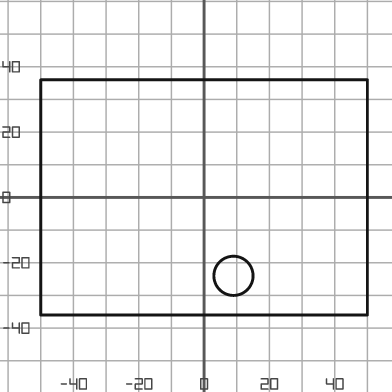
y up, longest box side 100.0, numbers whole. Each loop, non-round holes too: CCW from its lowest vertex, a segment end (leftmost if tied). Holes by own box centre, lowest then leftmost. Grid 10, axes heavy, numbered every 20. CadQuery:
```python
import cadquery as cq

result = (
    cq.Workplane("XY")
    .moveTo(-50.0, -36.0)
    .lineTo(50.0, -36.0)
    .lineTo(50.0, 36.0)
    .lineTo(-50.0, 36.0)
    .close()
    .moveTo(9.0, -24.0)
    .circle(6.0)
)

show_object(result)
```